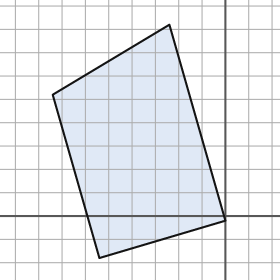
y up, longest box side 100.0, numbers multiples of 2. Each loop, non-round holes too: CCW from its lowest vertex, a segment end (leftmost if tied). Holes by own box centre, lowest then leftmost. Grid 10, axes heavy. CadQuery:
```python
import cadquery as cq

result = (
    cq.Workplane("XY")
    .moveTo(-54.0, -18.0)
    .lineTo(0.0, -2.0)
    .lineTo(-24.0, 82.0)
    .lineTo(-74.0, 52.0)
    .close()
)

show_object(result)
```